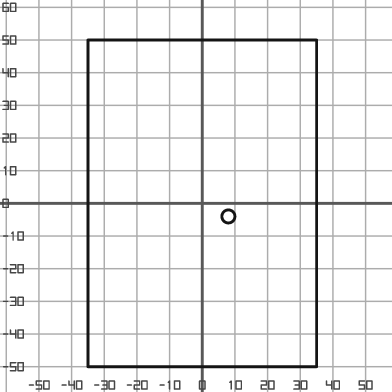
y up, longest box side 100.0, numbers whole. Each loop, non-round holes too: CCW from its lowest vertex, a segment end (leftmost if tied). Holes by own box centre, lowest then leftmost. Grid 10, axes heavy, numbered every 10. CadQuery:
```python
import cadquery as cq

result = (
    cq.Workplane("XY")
    .moveTo(-35.0, -50.0)
    .lineTo(35.0, -50.0)
    .lineTo(35.0, 50.0)
    .lineTo(-35.0, 50.0)
    .close()
    .moveTo(8.0, -4.0)
    .circle(2.0)
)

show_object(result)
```